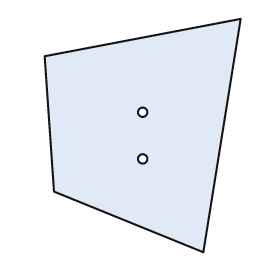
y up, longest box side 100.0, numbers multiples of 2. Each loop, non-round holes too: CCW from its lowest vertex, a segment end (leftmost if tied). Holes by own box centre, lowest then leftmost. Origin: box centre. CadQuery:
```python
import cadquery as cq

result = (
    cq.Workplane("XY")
    .moveTo(26.0, -50.0)
    .lineTo(42.0, 50.0)
    .lineTo(-42.0, 34.0)
    .lineTo(-38.0, -24.0)
    .close()
    .moveTo(0.0, -10.0)
    .circle(2.0)
    .moveTo(0.0, 10.0)
    .circle(2.0)
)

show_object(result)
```